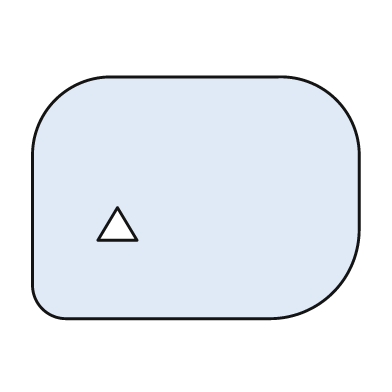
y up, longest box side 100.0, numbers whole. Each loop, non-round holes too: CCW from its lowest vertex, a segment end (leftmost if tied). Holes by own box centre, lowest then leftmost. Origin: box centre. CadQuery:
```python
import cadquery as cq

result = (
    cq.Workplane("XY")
    .moveTo(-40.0, -37.0)
    .lineTo(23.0, -37.0)
    .threePointArc((42.0, -29.0), (50.0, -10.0))
    .lineTo(50.0, 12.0)
    .threePointArc((43.0, 30.0), (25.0, 37.0))
    .lineTo(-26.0, 37.0)
    .threePointArc((-43.0, 30.0), (-50.0, 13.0))
    .lineTo(-50.0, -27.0)
    .threePointArc((-47.0, -34.0), (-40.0, -37.0))
    .close()
    .moveTo(-30.0, -13.0)
    .lineTo(-18.0, -13.0)
    .lineTo(-24.0, -3.0)
    .close()
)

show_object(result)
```